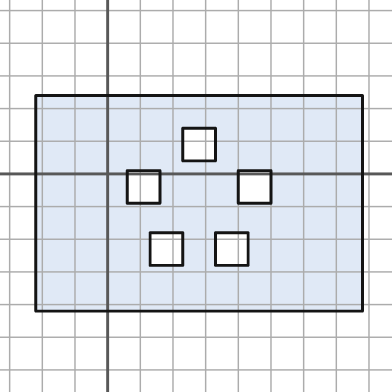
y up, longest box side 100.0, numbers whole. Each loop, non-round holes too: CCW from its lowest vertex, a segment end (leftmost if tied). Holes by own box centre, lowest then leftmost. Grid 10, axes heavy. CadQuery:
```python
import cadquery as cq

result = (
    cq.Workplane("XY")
    .moveTo(-22.0, -42.0)
    .lineTo(78.0, -42.0)
    .lineTo(78.0, 24.0)
    .lineTo(-22.0, 24.0)
    .close()
    .moveTo(13.0, -28.0)
    .lineTo(23.0, -28.0)
    .lineTo(23.0, -18.0)
    .lineTo(13.0, -18.0)
    .close()
    .moveTo(33.0, -28.0)
    .lineTo(43.0, -28.0)
    .lineTo(43.0, -18.0)
    .lineTo(33.0, -18.0)
    .close()
    .moveTo(6.0, -9.0)
    .lineTo(16.0, -9.0)
    .lineTo(16.0, 1.0)
    .lineTo(6.0, 1.0)
    .close()
    .moveTo(40.0, -9.0)
    .lineTo(50.0, -9.0)
    .lineTo(50.0, 1.0)
    .lineTo(40.0, 1.0)
    .close()
    .moveTo(23.0, 4.0)
    .lineTo(33.0, 4.0)
    .lineTo(33.0, 14.0)
    .lineTo(23.0, 14.0)
    .close()
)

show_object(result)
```